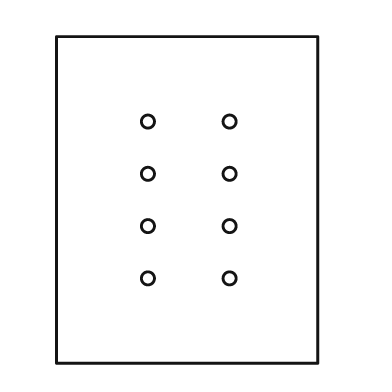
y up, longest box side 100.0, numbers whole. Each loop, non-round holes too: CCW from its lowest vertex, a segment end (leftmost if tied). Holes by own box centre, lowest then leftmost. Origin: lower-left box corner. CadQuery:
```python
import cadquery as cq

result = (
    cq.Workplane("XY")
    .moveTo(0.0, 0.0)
    .lineTo(80.0, 0.0)
    .lineTo(80.0, 100.0)
    .lineTo(0.0, 100.0)
    .close()
    .moveTo(28.0, 26.0)
    .circle(2.0)
    .moveTo(53.0, 26.0)
    .circle(2.0)
    .moveTo(28.0, 42.0)
    .circle(2.0)
    .moveTo(53.0, 42.0)
    .circle(2.0)
    .moveTo(28.0, 58.0)
    .circle(2.0)
    .moveTo(53.0, 58.0)
    .circle(2.0)
    .moveTo(28.0, 74.0)
    .circle(2.0)
    .moveTo(53.0, 74.0)
    .circle(2.0)
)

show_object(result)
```